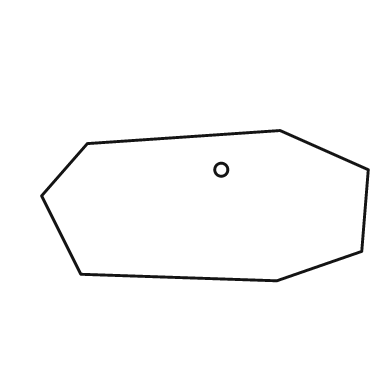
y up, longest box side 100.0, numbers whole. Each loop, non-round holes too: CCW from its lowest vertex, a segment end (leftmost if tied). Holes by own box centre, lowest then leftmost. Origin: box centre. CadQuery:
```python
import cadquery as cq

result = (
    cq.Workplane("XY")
    .moveTo(22.0, -23.0)
    .lineTo(48.0, -14.0)
    .lineTo(50.0, 11.0)
    .lineTo(23.0, 23.0)
    .lineTo(-36.0, 19.0)
    .lineTo(-50.0, 3.0)
    .lineTo(-38.0, -21.0)
    .close()
    .moveTo(5.0, 11.0)
    .circle(2.0)
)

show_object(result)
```